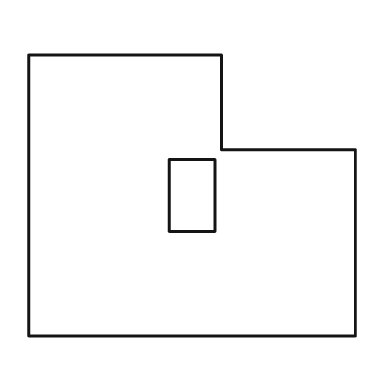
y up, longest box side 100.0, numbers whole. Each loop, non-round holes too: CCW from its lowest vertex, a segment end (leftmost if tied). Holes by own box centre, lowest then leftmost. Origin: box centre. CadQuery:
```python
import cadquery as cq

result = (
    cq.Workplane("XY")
    .moveTo(-50.0, -43.0)
    .lineTo(50.0, -43.0)
    .lineTo(50.0, 14.0)
    .lineTo(9.0, 14.0)
    .lineTo(9.0, 43.0)
    .lineTo(-50.0, 43.0)
    .close()
    .moveTo(-7.0, -11.0)
    .lineTo(7.0, -11.0)
    .lineTo(7.0, 11.0)
    .lineTo(-7.0, 11.0)
    .close()
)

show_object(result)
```